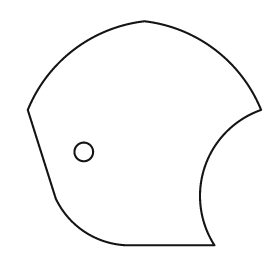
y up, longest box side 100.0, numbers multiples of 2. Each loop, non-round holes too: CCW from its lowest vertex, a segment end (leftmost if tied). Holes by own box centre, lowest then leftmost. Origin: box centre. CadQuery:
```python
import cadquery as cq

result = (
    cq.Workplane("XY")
    .moveTo(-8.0, -48.0)
    .lineTo(30.0, -48.0)
    .threePointArc((26.0, -14.0), (50.0, 10.0))
    .threePointArc((30.0, 36.0), (0.0, 48.0))
    .threePointArc((-30.0, 36.0), (-50.0, 10.0))
    .lineTo(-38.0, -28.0)
    .threePointArc((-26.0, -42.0), (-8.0, -48.0))
    .close()
    .moveTo(-26.0, -8.0)
    .circle(4.0)
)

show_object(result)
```